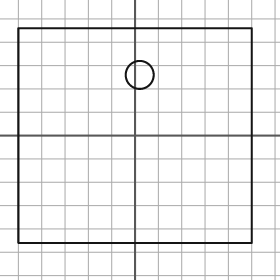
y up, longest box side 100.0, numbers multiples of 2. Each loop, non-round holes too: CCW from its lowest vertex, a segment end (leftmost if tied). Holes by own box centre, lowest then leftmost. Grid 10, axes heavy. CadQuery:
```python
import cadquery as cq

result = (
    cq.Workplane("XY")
    .moveTo(-50.0, -46.0)
    .lineTo(50.0, -46.0)
    .lineTo(50.0, 46.0)
    .lineTo(-50.0, 46.0)
    .close()
    .moveTo(2.0, 26.0)
    .circle(6.0)
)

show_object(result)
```